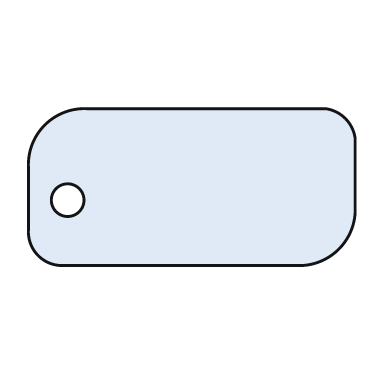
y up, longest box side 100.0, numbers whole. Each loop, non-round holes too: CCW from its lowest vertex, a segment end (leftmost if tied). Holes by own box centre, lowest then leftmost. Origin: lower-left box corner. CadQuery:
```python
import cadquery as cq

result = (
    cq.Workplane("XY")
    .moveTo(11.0, 0.0)
    .lineTo(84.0, 0.0)
    .threePointArc((95.0, 5.0), (100.0, 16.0))
    .lineTo(100.0, 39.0)
    .threePointArc((97.0, 45.0), (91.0, 48.0))
    .lineTo(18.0, 48.0)
    .threePointArc((5.0, 43.0), (0.0, 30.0))
    .lineTo(0.0, 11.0)
    .threePointArc((3.0, 3.0), (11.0, 0.0))
    .close()
    .moveTo(12.0, 20.0)
    .circle(5.0)
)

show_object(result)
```